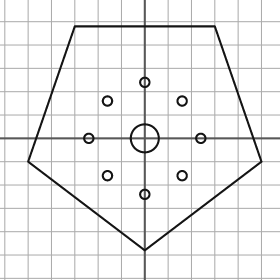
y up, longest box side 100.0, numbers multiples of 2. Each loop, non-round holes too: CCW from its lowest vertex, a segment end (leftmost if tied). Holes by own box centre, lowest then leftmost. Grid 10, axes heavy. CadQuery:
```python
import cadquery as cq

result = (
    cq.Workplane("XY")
    .moveTo(0.0, -48.0)
    .lineTo(50.0, -10.0)
    .lineTo(30.0, 48.0)
    .lineTo(-30.0, 48.0)
    .lineTo(-50.0, -10.0)
    .close()
    .moveTo(0.0, -24.0)
    .circle(2.0)
    .moveTo(-16.0, -16.0)
    .circle(2.0)
    .moveTo(16.0, -16.0)
    .circle(2.0)
    .moveTo(-24.0, 0.0)
    .circle(2.0)
    .moveTo(0.0, 0.0)
    .circle(6.0)
    .moveTo(24.0, 0.0)
    .circle(2.0)
    .moveTo(-16.0, 16.0)
    .circle(2.0)
    .moveTo(16.0, 16.0)
    .circle(2.0)
    .moveTo(0.0, 24.0)
    .circle(2.0)
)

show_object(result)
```